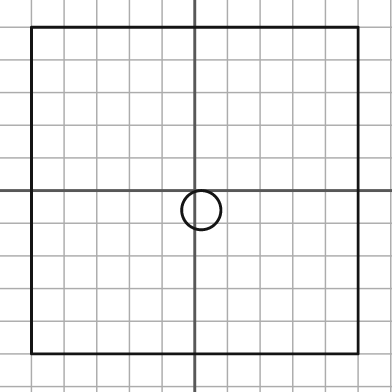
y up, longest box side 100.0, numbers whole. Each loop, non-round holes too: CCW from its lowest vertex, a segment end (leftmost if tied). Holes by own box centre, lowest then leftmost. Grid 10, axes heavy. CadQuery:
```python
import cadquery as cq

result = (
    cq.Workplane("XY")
    .moveTo(-50.0, -50.0)
    .lineTo(50.0, -50.0)
    .lineTo(50.0, 50.0)
    .lineTo(-50.0, 50.0)
    .close()
    .moveTo(2.0, -6.0)
    .circle(6.0)
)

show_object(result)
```